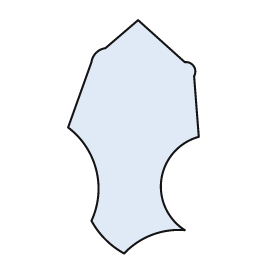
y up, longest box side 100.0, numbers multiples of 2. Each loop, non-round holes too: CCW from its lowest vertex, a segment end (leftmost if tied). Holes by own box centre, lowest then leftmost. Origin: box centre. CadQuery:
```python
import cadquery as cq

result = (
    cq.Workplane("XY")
    .moveTo(-4.0, -50.0)
    .threePointArc((8.0, -42.0), (22.0, -40.0))
    .threePointArc((12.0, -18.0), (28.0, 0.0))
    .lineTo(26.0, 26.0)
    .threePointArc((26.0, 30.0), (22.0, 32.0))
    .lineTo(2.0, 50.0)
    .lineTo(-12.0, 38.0)
    .threePointArc((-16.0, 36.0), (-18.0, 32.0))
    .lineTo(-28.0, 4.0)
    .threePointArc((-16.0, -14.0), (-18.0, -36.0))
    .threePointArc((-12.0, -44.0), (-4.0, -50.0))
    .close()
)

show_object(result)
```